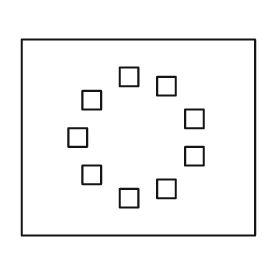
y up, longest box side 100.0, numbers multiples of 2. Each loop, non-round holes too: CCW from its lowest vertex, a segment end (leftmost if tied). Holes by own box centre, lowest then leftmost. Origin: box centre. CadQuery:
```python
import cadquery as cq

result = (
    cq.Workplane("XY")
    .moveTo(-50.0, -42.0)
    .lineTo(50.0, -42.0)
    .lineTo(50.0, 42.0)
    .lineTo(-50.0, 42.0)
    .close()
    .moveTo(-8.0, -30.0)
    .lineTo(0.0, -30.0)
    .lineTo(0.0, -22.0)
    .lineTo(-8.0, -22.0)
    .close()
    .moveTo(8.0, -26.0)
    .lineTo(16.0, -26.0)
    .lineTo(16.0, -18.0)
    .lineTo(8.0, -18.0)
    .close()
    .moveTo(-24.0, -20.0)
    .lineTo(-16.0, -20.0)
    .lineTo(-16.0, -12.0)
    .lineTo(-24.0, -12.0)
    .close()
    .moveTo(20.0, -12.0)
    .lineTo(28.0, -12.0)
    .lineTo(28.0, -4.0)
    .lineTo(20.0, -4.0)
    .close()
    .moveTo(-30.0, -4.0)
    .lineTo(-22.0, -4.0)
    .lineTo(-22.0, 4.0)
    .lineTo(-30.0, 4.0)
    .close()
    .moveTo(20.0, 4.0)
    .lineTo(28.0, 4.0)
    .lineTo(28.0, 12.0)
    .lineTo(20.0, 12.0)
    .close()
    .moveTo(-24.0, 12.0)
    .lineTo(-16.0, 12.0)
    .lineTo(-16.0, 20.0)
    .lineTo(-24.0, 20.0)
    .close()
    .moveTo(8.0, 18.0)
    .lineTo(16.0, 18.0)
    .lineTo(16.0, 26.0)
    .lineTo(8.0, 26.0)
    .close()
    .moveTo(-8.0, 22.0)
    .lineTo(0.0, 22.0)
    .lineTo(0.0, 30.0)
    .lineTo(-8.0, 30.0)
    .close()
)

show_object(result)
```